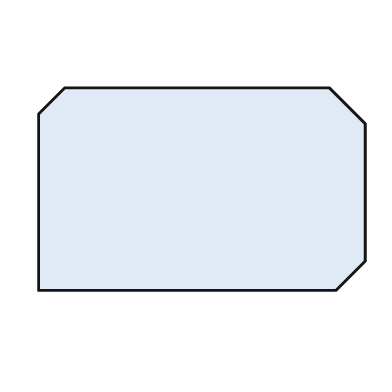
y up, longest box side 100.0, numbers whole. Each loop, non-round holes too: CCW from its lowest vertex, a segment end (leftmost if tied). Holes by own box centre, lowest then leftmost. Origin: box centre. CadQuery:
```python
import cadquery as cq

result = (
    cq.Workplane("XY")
    .moveTo(-50.0, -31.0)
    .lineTo(41.0, -31.0)
    .lineTo(50.0, -22.0)
    .lineTo(50.0, 20.0)
    .lineTo(39.0, 31.0)
    .lineTo(-42.0, 31.0)
    .lineTo(-50.0, 23.0)
    .close()
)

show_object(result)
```